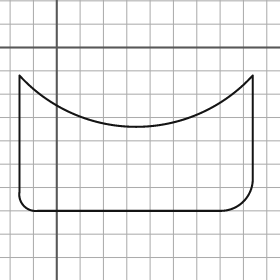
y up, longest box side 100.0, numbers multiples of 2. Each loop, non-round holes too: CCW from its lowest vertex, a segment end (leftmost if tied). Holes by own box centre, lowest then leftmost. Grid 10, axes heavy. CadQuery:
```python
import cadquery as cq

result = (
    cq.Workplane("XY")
    .moveTo(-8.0, -70.0)
    .lineTo(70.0, -70.0)
    .threePointArc((80.0, -66.0), (84.0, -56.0))
    .lineTo(84.0, -12.0)
    .threePointArc((34.0, -34.0), (-16.0, -12.0))
    .lineTo(-16.0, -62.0)
    .threePointArc((-14.0, -68.0), (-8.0, -70.0))
    .close()
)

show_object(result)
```